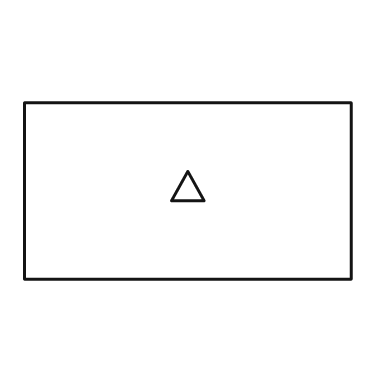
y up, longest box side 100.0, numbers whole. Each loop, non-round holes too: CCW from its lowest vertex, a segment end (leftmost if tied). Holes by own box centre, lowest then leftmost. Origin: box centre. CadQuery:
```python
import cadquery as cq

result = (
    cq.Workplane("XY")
    .moveTo(-50.0, -27.0)
    .lineTo(50.0, -27.0)
    .lineTo(50.0, 27.0)
    .lineTo(-50.0, 27.0)
    .close()
    .moveTo(-5.0, -3.0)
    .lineTo(5.0, -3.0)
    .lineTo(0.0, 6.0)
    .close()
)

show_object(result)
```